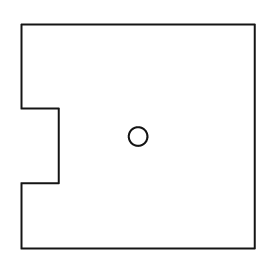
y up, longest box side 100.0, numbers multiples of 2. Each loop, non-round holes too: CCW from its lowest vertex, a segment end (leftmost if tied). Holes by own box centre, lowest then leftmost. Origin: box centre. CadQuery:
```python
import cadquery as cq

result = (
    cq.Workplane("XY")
    .moveTo(-50.0, -48.0)
    .lineTo(50.0, -48.0)
    .lineTo(50.0, 48.0)
    .lineTo(-50.0, 48.0)
    .lineTo(-50.0, 12.0)
    .lineTo(-34.0, 12.0)
    .lineTo(-34.0, -20.0)
    .lineTo(-50.0, -20.0)
    .close()
    .moveTo(0.0, 0.0)
    .circle(4.0)
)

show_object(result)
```